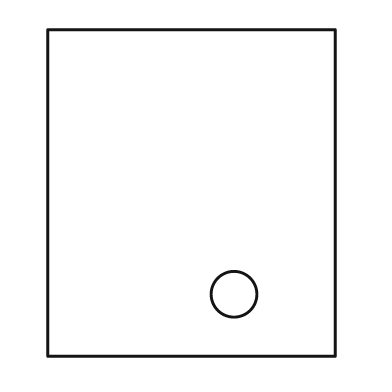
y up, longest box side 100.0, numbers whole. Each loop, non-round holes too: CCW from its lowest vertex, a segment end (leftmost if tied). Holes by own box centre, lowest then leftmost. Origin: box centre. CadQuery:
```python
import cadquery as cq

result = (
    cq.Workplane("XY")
    .moveTo(-44.0, -50.0)
    .lineTo(44.0, -50.0)
    .lineTo(44.0, 50.0)
    .lineTo(-44.0, 50.0)
    .close()
    .moveTo(13.0, -31.0)
    .circle(7.0)
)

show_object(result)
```